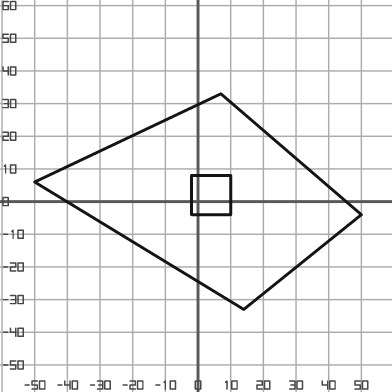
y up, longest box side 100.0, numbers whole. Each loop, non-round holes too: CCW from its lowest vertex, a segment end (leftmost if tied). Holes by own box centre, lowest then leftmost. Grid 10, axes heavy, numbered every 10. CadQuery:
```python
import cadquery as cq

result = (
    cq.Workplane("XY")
    .moveTo(14.0, -33.0)
    .lineTo(50.0, -4.0)
    .lineTo(7.0, 33.0)
    .lineTo(-50.0, 6.0)
    .close()
    .moveTo(-2.0, -4.0)
    .lineTo(10.0, -4.0)
    .lineTo(10.0, 8.0)
    .lineTo(-2.0, 8.0)
    .close()
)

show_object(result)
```